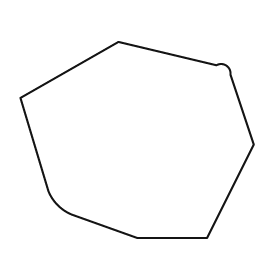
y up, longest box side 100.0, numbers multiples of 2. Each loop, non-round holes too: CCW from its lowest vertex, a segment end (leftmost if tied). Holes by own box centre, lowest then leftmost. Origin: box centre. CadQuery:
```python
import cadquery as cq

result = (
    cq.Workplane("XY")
    .moveTo(0.0, -42.0)
    .lineTo(30.0, -42.0)
    .lineTo(50.0, -2.0)
    .lineTo(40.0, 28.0)
    .threePointArc((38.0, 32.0), (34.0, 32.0))
    .lineTo(-8.0, 42.0)
    .lineTo(-50.0, 18.0)
    .lineTo(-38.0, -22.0)
    .threePointArc((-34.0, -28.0), (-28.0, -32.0))
    .close()
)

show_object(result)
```